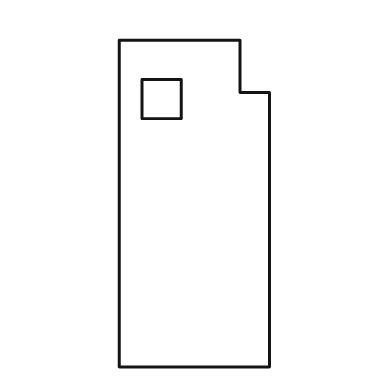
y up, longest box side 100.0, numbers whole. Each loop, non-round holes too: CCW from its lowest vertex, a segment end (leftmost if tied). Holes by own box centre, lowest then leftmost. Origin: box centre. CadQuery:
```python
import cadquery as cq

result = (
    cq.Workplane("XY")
    .moveTo(-23.0, -50.0)
    .lineTo(23.0, -50.0)
    .lineTo(23.0, 34.0)
    .lineTo(14.0, 34.0)
    .lineTo(14.0, 50.0)
    .lineTo(-23.0, 50.0)
    .close()
    .moveTo(-16.0, 26.0)
    .lineTo(-4.0, 26.0)
    .lineTo(-4.0, 38.0)
    .lineTo(-16.0, 38.0)
    .close()
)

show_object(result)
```